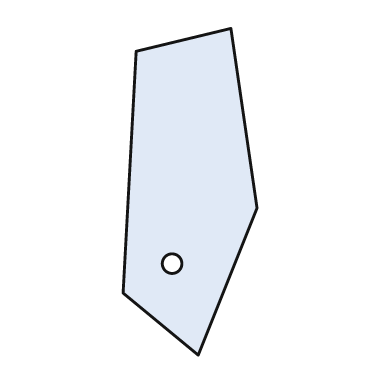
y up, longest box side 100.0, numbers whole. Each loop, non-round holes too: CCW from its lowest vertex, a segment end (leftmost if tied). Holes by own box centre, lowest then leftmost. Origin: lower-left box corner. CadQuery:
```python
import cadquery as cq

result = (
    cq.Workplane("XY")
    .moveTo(23.0, 0.0)
    .lineTo(41.0, 45.0)
    .lineTo(33.0, 100.0)
    .lineTo(4.0, 93.0)
    .lineTo(0.0, 19.0)
    .close()
    .moveTo(15.0, 28.0)
    .circle(3.0)
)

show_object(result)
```